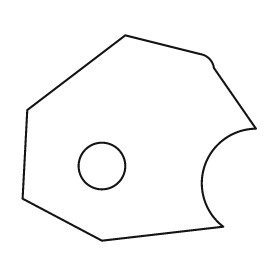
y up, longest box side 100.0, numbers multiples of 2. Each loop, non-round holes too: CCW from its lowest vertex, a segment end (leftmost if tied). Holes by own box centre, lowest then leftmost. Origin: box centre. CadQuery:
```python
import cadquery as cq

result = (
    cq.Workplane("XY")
    .moveTo(-16.0, -44.0)
    .lineTo(36.0, -38.0)
    .threePointArc((28.0, -12.0), (50.0, 4.0))
    .lineTo(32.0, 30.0)
    .threePointArc((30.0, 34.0), (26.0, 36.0))
    .lineTo(-6.0, 44.0)
    .lineTo(-48.0, 12.0)
    .lineTo(-50.0, -26.0)
    .close()
    .moveTo(-16.0, -12.0)
    .circle(10.0)
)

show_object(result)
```